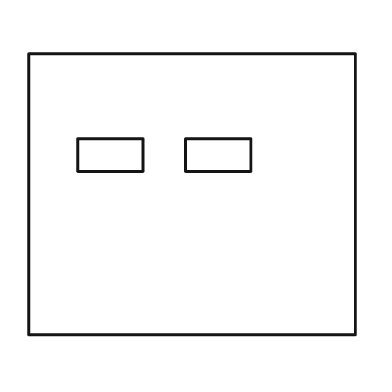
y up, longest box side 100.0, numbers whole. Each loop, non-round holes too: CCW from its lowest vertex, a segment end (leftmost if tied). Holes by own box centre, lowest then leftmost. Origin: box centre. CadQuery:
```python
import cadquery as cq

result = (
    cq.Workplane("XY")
    .moveTo(-50.0, -43.0)
    .lineTo(50.0, -43.0)
    .lineTo(50.0, 43.0)
    .lineTo(-50.0, 43.0)
    .close()
    .moveTo(-35.0, 7.0)
    .lineTo(-15.0, 7.0)
    .lineTo(-15.0, 17.0)
    .lineTo(-35.0, 17.0)
    .close()
    .moveTo(-2.0, 7.0)
    .lineTo(18.0, 7.0)
    .lineTo(18.0, 17.0)
    .lineTo(-2.0, 17.0)
    .close()
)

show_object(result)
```